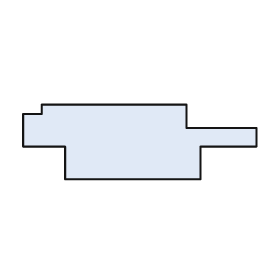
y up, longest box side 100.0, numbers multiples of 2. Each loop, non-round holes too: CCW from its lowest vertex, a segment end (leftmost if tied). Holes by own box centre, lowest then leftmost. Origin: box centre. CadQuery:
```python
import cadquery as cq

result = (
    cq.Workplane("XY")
    .moveTo(-32.0, -16.0)
    .lineTo(26.0, -16.0)
    .lineTo(26.0, -2.0)
    .lineTo(50.0, -2.0)
    .lineTo(50.0, 6.0)
    .lineTo(20.0, 6.0)
    .lineTo(20.0, 16.0)
    .lineTo(-42.0, 16.0)
    .lineTo(-42.0, 12.0)
    .lineTo(-50.0, 12.0)
    .lineTo(-50.0, -2.0)
    .lineTo(-32.0, -2.0)
    .close()
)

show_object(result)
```